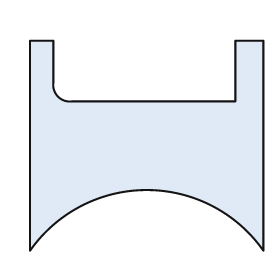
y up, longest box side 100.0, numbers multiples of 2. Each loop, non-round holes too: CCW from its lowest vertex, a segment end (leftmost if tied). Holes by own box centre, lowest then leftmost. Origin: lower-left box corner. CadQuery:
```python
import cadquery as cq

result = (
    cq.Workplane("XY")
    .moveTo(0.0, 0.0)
    .threePointArc((50.0, 26.0), (100.0, 0.0))
    .lineTo(100.0, 90.0)
    .lineTo(88.0, 90.0)
    .lineTo(88.0, 64.0)
    .lineTo(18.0, 64.0)
    .threePointArc((12.0, 66.0), (10.0, 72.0))
    .lineTo(10.0, 90.0)
    .lineTo(0.0, 90.0)
    .close()
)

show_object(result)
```